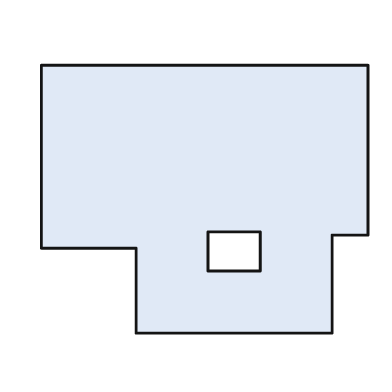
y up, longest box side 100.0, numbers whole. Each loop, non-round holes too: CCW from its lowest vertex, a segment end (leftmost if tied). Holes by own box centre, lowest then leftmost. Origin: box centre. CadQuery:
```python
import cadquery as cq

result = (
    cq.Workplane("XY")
    .moveTo(-21.0, -41.0)
    .lineTo(39.0, -41.0)
    .lineTo(39.0, -11.0)
    .lineTo(50.0, -11.0)
    .lineTo(50.0, 41.0)
    .lineTo(-50.0, 41.0)
    .lineTo(-50.0, -15.0)
    .lineTo(-21.0, -15.0)
    .close()
    .moveTo(1.0, -22.0)
    .lineTo(17.0, -22.0)
    .lineTo(17.0, -10.0)
    .lineTo(1.0, -10.0)
    .close()
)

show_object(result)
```